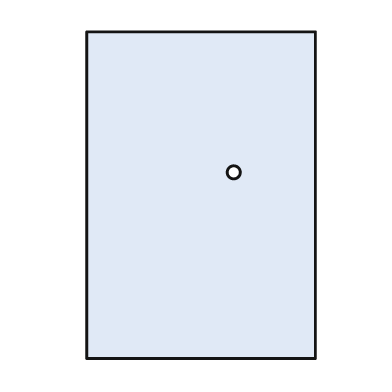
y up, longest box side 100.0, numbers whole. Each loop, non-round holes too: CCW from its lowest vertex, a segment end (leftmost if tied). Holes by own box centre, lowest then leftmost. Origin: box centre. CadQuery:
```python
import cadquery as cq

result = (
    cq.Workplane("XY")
    .moveTo(-35.0, -50.0)
    .lineTo(35.0, -50.0)
    .lineTo(35.0, 50.0)
    .lineTo(-35.0, 50.0)
    .close()
    .moveTo(10.0, 7.0)
    .circle(2.0)
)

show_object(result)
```